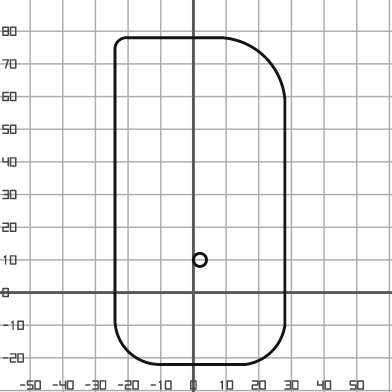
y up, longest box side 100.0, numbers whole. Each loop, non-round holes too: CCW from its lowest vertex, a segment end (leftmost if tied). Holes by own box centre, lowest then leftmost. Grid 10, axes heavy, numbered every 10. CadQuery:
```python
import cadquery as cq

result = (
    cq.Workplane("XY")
    .moveTo(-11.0, -22.0)
    .lineTo(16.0, -22.0)
    .threePointArc((24.0, -18.0), (28.0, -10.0))
    .lineTo(28.0, 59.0)
    .threePointArc((22.0, 72.0), (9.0, 78.0))
    .lineTo(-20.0, 78.0)
    .threePointArc((-23.0, 77.0), (-24.0, 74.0))
    .lineTo(-24.0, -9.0)
    .threePointArc((-20.0, -18.0), (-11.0, -22.0))
    .close()
    .moveTo(2.0, 10.0)
    .circle(2.0)
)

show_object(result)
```